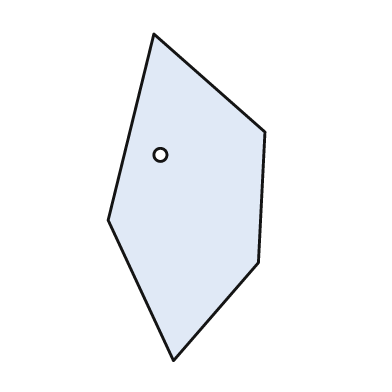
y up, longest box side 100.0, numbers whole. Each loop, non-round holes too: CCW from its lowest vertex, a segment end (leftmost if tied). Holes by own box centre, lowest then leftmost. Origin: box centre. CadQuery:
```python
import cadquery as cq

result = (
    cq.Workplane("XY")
    .moveTo(-4.0, -50.0)
    .lineTo(22.0, -20.0)
    .lineTo(24.0, 20.0)
    .lineTo(-10.0, 50.0)
    .lineTo(-24.0, -7.0)
    .close()
    .moveTo(-8.0, 13.0)
    .circle(2.0)
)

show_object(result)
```